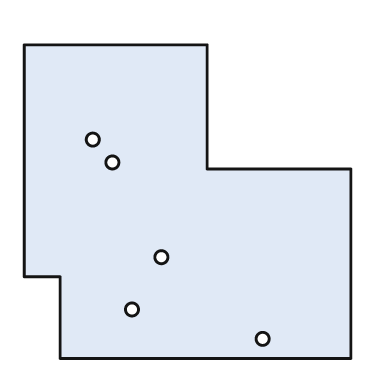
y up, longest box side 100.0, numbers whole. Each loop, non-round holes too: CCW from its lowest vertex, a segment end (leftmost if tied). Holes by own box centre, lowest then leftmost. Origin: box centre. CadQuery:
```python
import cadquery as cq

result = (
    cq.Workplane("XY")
    .moveTo(-39.0, -48.0)
    .lineTo(50.0, -48.0)
    .lineTo(50.0, 10.0)
    .lineTo(6.0, 10.0)
    .lineTo(6.0, 48.0)
    .lineTo(-50.0, 48.0)
    .lineTo(-50.0, -23.0)
    .lineTo(-39.0, -23.0)
    .close()
    .moveTo(23.0, -42.0)
    .circle(2.0)
    .moveTo(-17.0, -33.0)
    .circle(2.0)
    .moveTo(-8.0, -17.0)
    .circle(2.0)
    .moveTo(-23.0, 12.0)
    .circle(2.0)
    .moveTo(-29.0, 19.0)
    .circle(2.0)
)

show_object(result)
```